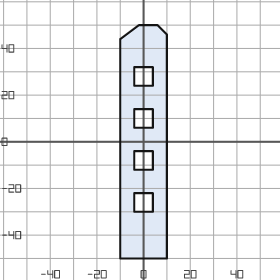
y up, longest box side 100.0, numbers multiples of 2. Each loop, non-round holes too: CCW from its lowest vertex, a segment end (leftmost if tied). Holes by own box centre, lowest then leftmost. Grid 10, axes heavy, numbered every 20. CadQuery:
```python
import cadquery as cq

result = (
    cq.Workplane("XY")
    .moveTo(-10.0, -50.0)
    .lineTo(10.0, -50.0)
    .lineTo(10.0, 46.0)
    .lineTo(6.0, 50.0)
    .lineTo(-2.0, 50.0)
    .lineTo(-10.0, 44.0)
    .close()
    .moveTo(-4.0, -30.0)
    .lineTo(4.0, -30.0)
    .lineTo(4.0, -22.0)
    .lineTo(-4.0, -22.0)
    .close()
    .moveTo(-4.0, -12.0)
    .lineTo(4.0, -12.0)
    .lineTo(4.0, -4.0)
    .lineTo(-4.0, -4.0)
    .close()
    .moveTo(-4.0, 6.0)
    .lineTo(4.0, 6.0)
    .lineTo(4.0, 14.0)
    .lineTo(-4.0, 14.0)
    .close()
    .moveTo(-4.0, 24.0)
    .lineTo(4.0, 24.0)
    .lineTo(4.0, 32.0)
    .lineTo(-4.0, 32.0)
    .close()
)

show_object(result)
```